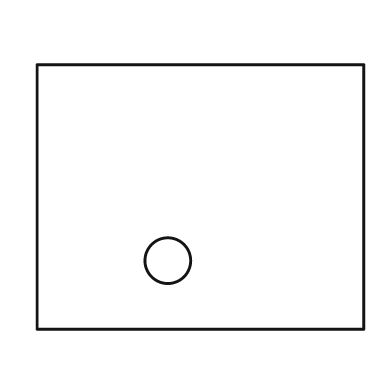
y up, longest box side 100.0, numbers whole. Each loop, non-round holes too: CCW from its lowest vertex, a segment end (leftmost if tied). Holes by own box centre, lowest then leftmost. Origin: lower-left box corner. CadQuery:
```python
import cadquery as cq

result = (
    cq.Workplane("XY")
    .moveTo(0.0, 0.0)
    .lineTo(100.0, 0.0)
    .lineTo(100.0, 81.0)
    .lineTo(0.0, 81.0)
    .close()
    .moveTo(40.0, 21.0)
    .circle(7.0)
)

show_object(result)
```